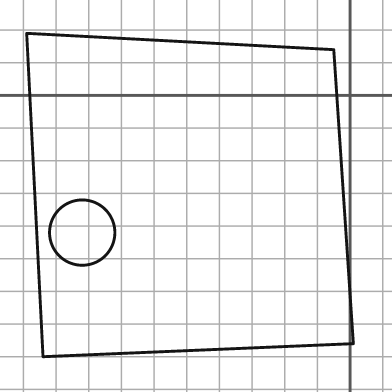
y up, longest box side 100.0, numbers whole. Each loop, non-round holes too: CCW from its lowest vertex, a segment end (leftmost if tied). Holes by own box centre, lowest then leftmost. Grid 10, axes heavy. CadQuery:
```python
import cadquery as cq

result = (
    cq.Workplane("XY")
    .moveTo(-94.0, -80.0)
    .lineTo(1.0, -76.0)
    .lineTo(-5.0, 14.0)
    .lineTo(-99.0, 19.0)
    .close()
    .moveTo(-82.0, -42.0)
    .circle(10.0)
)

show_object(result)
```